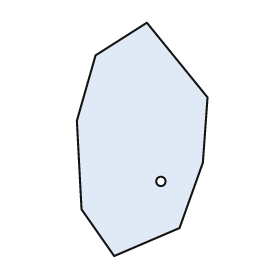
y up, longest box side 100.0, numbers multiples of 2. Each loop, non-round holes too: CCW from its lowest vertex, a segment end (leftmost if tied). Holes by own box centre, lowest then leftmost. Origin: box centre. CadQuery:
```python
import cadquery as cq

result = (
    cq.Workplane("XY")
    .moveTo(-12.0, -50.0)
    .lineTo(16.0, -38.0)
    .lineTo(26.0, -10.0)
    .lineTo(28.0, 18.0)
    .lineTo(2.0, 50.0)
    .lineTo(-20.0, 36.0)
    .lineTo(-28.0, 8.0)
    .lineTo(-26.0, -30.0)
    .close()
    .moveTo(8.0, -18.0)
    .circle(2.0)
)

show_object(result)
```